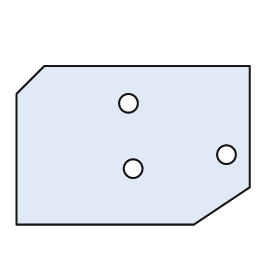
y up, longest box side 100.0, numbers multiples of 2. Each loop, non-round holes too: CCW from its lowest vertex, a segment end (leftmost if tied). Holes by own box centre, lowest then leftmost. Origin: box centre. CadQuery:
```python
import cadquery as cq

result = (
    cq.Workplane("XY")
    .moveTo(-50.0, -34.0)
    .lineTo(26.0, -34.0)
    .lineTo(50.0, -18.0)
    .lineTo(50.0, 34.0)
    .lineTo(-38.0, 34.0)
    .lineTo(-50.0, 22.0)
    .close()
    .moveTo(0.0, -10.0)
    .circle(4.0)
    .moveTo(40.0, -4.0)
    .circle(4.0)
    .moveTo(-2.0, 18.0)
    .circle(4.0)
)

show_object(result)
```